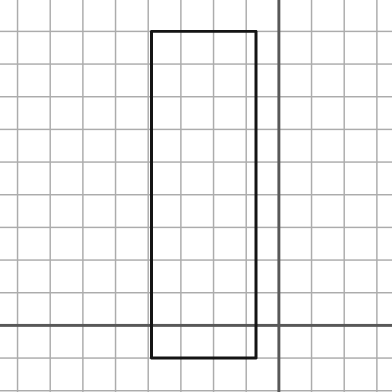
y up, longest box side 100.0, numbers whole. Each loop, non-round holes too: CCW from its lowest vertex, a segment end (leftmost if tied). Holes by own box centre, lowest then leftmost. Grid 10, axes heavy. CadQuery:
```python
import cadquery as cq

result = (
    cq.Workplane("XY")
    .moveTo(-39.0, -10.0)
    .lineTo(-7.0, -10.0)
    .lineTo(-7.0, 90.0)
    .lineTo(-39.0, 90.0)
    .close()
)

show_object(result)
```